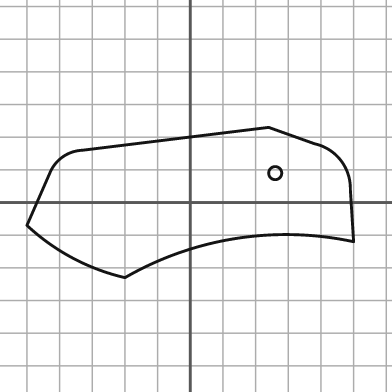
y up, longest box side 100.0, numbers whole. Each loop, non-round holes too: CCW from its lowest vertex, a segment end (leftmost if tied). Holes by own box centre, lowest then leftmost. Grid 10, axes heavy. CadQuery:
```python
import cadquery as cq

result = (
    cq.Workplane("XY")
    .moveTo(-20.0, -23.0)
    .threePointArc((14.0, -11.0), (50.0, -12.0))
    .lineTo(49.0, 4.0)
    .threePointArc((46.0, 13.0), (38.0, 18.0))
    .lineTo(24.0, 23.0)
    .lineTo(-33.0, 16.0)
    .threePointArc((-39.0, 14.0), (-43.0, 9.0))
    .lineTo(-50.0, -7.0)
    .threePointArc((-36.0, -17.0), (-20.0, -23.0))
    .close()
    .moveTo(26.0, 9.0)
    .circle(2.0)
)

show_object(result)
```